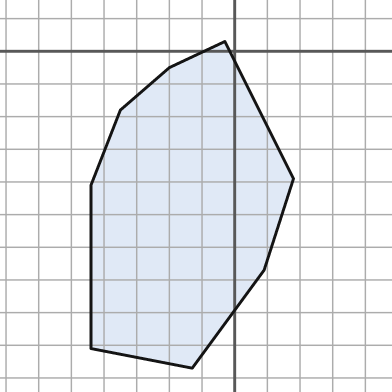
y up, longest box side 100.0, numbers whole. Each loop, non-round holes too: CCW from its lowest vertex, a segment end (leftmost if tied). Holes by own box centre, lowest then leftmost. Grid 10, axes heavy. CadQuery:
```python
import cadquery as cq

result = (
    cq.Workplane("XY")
    .moveTo(-13.0, -97.0)
    .lineTo(9.0, -67.0)
    .lineTo(18.0, -39.0)
    .lineTo(-3.0, 3.0)
    .lineTo(-20.0, -5.0)
    .lineTo(-35.0, -18.0)
    .lineTo(-44.0, -41.0)
    .lineTo(-44.0, -91.0)
    .close()
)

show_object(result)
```